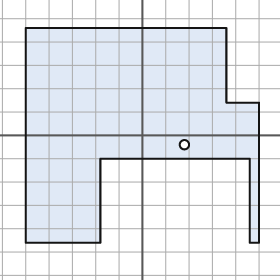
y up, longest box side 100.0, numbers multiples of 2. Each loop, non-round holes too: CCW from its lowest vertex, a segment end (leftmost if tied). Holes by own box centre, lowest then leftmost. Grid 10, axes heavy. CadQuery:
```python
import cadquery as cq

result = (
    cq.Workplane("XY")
    .moveTo(-50.0, -46.0)
    .lineTo(-18.0, -46.0)
    .lineTo(-18.0, -10.0)
    .lineTo(46.0, -10.0)
    .lineTo(46.0, -46.0)
    .lineTo(50.0, -46.0)
    .lineTo(50.0, 14.0)
    .lineTo(36.0, 14.0)
    .lineTo(36.0, 46.0)
    .lineTo(-50.0, 46.0)
    .close()
    .moveTo(18.0, -4.0)
    .circle(2.0)
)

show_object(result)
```